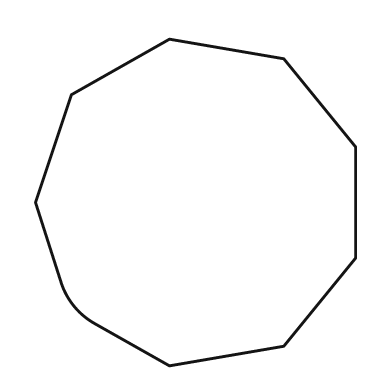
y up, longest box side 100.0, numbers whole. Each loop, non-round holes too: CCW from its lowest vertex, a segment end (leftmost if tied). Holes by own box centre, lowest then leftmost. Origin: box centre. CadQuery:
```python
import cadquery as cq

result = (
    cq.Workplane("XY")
    .moveTo(-8.0, -50.0)
    .lineTo(27.0, -44.0)
    .lineTo(49.0, -17.0)
    .lineTo(49.0, 17.0)
    .lineTo(27.0, 44.0)
    .lineTo(-8.0, 50.0)
    .lineTo(-38.0, 33.0)
    .lineTo(-49.0, 0.0)
    .lineTo(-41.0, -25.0)
    .threePointArc((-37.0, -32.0), (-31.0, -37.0))
    .close()
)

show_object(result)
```